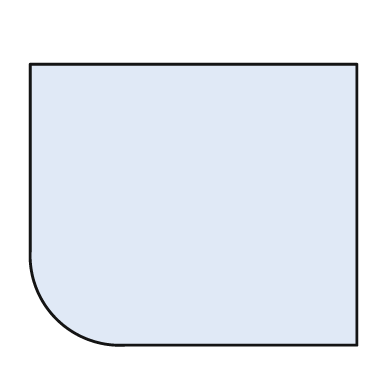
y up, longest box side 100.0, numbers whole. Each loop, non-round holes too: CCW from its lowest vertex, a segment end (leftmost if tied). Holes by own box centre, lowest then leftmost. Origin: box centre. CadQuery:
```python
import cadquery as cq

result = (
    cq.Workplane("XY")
    .moveTo(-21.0, -43.0)
    .lineTo(50.0, -43.0)
    .lineTo(50.0, 43.0)
    .lineTo(-50.0, 43.0)
    .lineTo(-50.0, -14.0)
    .threePointArc((-42.0, -35.0), (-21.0, -43.0))
    .close()
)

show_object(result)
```